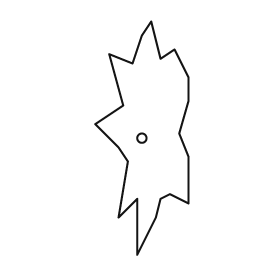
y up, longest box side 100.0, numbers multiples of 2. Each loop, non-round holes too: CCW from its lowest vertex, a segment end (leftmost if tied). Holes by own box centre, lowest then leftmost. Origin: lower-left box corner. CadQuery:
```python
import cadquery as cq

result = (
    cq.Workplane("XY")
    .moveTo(18.0, 0.0)
    .lineTo(26.0, 16.0)
    .lineTo(28.0, 24.0)
    .lineTo(32.0, 26.0)
    .lineTo(40.0, 22.0)
    .lineTo(40.0, 42.0)
    .lineTo(36.0, 52.0)
    .lineTo(40.0, 66.0)
    .lineTo(40.0, 76.0)
    .lineTo(34.0, 88.0)
    .lineTo(28.0, 84.0)
    .lineTo(24.0, 100.0)
    .lineTo(20.0, 94.0)
    .lineTo(16.0, 82.0)
    .lineTo(6.0, 86.0)
    .lineTo(12.0, 64.0)
    .lineTo(0.0, 56.0)
    .lineTo(10.0, 46.0)
    .lineTo(14.0, 40.0)
    .lineTo(10.0, 16.0)
    .lineTo(18.0, 24.0)
    .close()
    .moveTo(20.0, 50.0)
    .circle(2.0)
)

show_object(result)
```